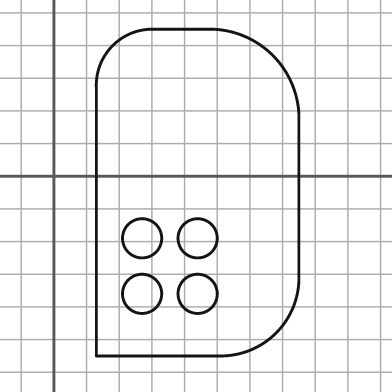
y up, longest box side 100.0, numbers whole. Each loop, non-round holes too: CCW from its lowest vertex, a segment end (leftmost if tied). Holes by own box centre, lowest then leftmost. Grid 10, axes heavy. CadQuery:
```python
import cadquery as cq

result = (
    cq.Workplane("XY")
    .moveTo(13.0, -55.0)
    .lineTo(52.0, -55.0)
    .threePointArc((68.0, -48.0), (75.0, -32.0))
    .lineTo(75.0, 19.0)
    .threePointArc((67.0, 37.0), (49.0, 45.0))
    .lineTo(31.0, 45.0)
    .threePointArc((18.0, 40.0), (13.0, 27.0))
    .close()
    .moveTo(27.0, -36.0)
    .circle(6.0)
    .moveTo(44.0, -36.0)
    .circle(6.0)
    .moveTo(27.0, -19.0)
    .circle(6.0)
    .moveTo(44.0, -19.0)
    .circle(6.0)
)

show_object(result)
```